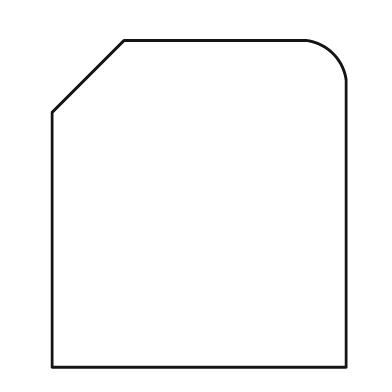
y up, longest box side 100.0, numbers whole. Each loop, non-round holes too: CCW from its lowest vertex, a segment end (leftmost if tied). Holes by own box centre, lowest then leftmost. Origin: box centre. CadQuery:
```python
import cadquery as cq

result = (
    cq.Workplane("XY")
    .moveTo(-45.0, -50.0)
    .lineTo(45.0, -50.0)
    .lineTo(45.0, 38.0)
    .threePointArc((41.0, 46.0), (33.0, 50.0))
    .lineTo(-23.0, 50.0)
    .lineTo(-45.0, 28.0)
    .close()
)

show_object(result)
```